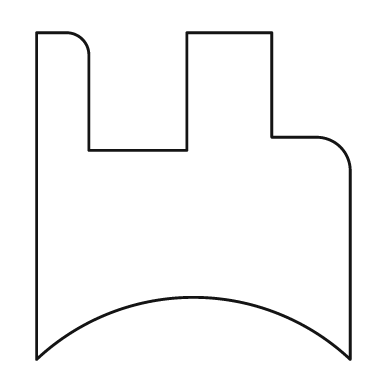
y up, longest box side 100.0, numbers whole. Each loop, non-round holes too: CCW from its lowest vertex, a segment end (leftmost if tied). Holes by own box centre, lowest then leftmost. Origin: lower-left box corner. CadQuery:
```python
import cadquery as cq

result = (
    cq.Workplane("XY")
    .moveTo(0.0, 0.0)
    .threePointArc((48.0, 19.0), (96.0, 0.0))
    .lineTo(96.0, 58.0)
    .threePointArc((93.0, 65.0), (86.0, 68.0))
    .lineTo(72.0, 68.0)
    .lineTo(72.0, 100.0)
    .lineTo(46.0, 100.0)
    .lineTo(46.0, 64.0)
    .lineTo(16.0, 64.0)
    .lineTo(16.0, 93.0)
    .threePointArc((14.0, 98.0), (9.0, 100.0))
    .lineTo(0.0, 100.0)
    .close()
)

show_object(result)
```